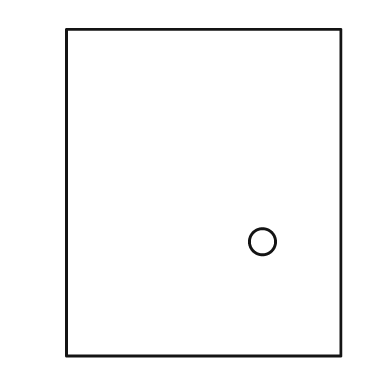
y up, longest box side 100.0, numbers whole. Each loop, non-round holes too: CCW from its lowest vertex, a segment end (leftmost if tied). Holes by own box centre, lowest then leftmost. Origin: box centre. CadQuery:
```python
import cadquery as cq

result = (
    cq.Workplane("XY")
    .moveTo(-42.0, -50.0)
    .lineTo(42.0, -50.0)
    .lineTo(42.0, 50.0)
    .lineTo(-42.0, 50.0)
    .close()
    .moveTo(18.0, -15.0)
    .circle(4.0)
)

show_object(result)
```